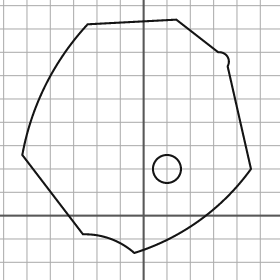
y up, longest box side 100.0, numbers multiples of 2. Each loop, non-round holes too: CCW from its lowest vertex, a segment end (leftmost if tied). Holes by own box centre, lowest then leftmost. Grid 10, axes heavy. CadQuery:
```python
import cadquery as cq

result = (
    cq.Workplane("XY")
    .moveTo(-4.0, -16.0)
    .threePointArc((24.0, -2.0), (46.0, 20.0))
    .lineTo(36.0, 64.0)
    .threePointArc((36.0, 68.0), (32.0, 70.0))
    .lineTo(14.0, 84.0)
    .lineTo(-24.0, 82.0)
    .threePointArc((-42.0, 56.0), (-52.0, 26.0))
    .lineTo(-26.0, -8.0)
    .threePointArc((-14.0, -10.0), (-4.0, -16.0))
    .close()
    .moveTo(10.0, 20.0)
    .circle(6.0)
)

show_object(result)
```